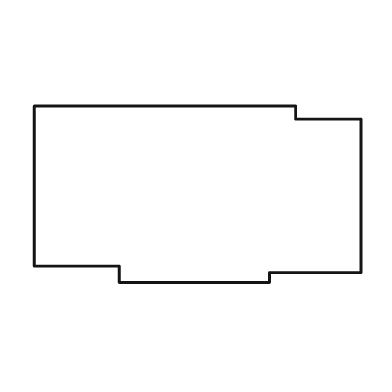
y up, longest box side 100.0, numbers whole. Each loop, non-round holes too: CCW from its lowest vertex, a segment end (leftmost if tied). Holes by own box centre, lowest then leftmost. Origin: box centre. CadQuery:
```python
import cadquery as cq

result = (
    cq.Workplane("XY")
    .moveTo(-24.0, -27.0)
    .lineTo(22.0, -27.0)
    .lineTo(22.0, -24.0)
    .lineTo(50.0, -24.0)
    .lineTo(50.0, 23.0)
    .lineTo(30.0, 23.0)
    .lineTo(30.0, 27.0)
    .lineTo(-50.0, 27.0)
    .lineTo(-50.0, -22.0)
    .lineTo(-24.0, -22.0)
    .close()
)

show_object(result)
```